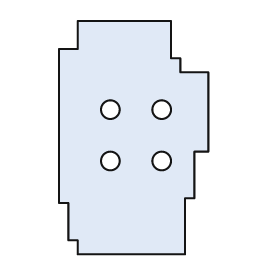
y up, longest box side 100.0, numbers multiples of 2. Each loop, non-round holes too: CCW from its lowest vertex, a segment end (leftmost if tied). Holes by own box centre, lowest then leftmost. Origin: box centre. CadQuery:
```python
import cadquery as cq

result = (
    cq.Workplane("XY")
    .moveTo(-24.0, -50.0)
    .lineTo(22.0, -50.0)
    .lineTo(22.0, -26.0)
    .lineTo(26.0, -26.0)
    .lineTo(26.0, -6.0)
    .lineTo(32.0, -6.0)
    .lineTo(32.0, 28.0)
    .lineTo(20.0, 28.0)
    .lineTo(20.0, 34.0)
    .lineTo(16.0, 34.0)
    .lineTo(16.0, 50.0)
    .lineTo(-24.0, 50.0)
    .lineTo(-24.0, 38.0)
    .lineTo(-32.0, 38.0)
    .lineTo(-32.0, -28.0)
    .lineTo(-28.0, -28.0)
    .lineTo(-28.0, -44.0)
    .lineTo(-24.0, -44.0)
    .close()
    .moveTo(-10.0, -10.0)
    .circle(4.0)
    .moveTo(12.0, -10.0)
    .circle(4.0)
    .moveTo(-10.0, 12.0)
    .circle(4.0)
    .moveTo(12.0, 12.0)
    .circle(4.0)
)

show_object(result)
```